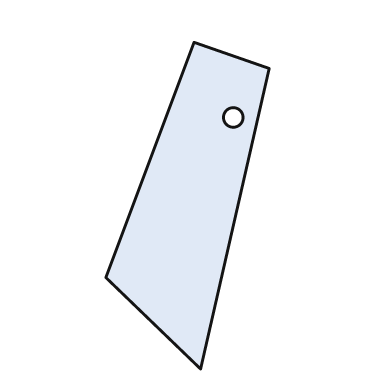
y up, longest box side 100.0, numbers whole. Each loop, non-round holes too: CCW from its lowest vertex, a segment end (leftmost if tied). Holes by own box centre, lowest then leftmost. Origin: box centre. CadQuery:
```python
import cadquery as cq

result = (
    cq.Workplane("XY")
    .moveTo(4.0, -50.0)
    .lineTo(25.0, 42.0)
    .lineTo(2.0, 50.0)
    .lineTo(-25.0, -22.0)
    .close()
    .moveTo(14.0, 27.0)
    .circle(3.0)
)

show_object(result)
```